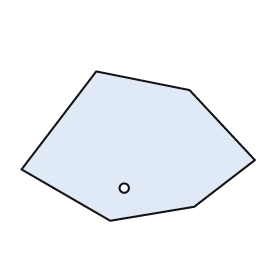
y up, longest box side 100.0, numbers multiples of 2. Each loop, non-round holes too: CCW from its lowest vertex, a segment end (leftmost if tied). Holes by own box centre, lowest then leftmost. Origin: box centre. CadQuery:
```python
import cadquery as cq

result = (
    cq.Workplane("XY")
    .moveTo(-12.0, -32.0)
    .lineTo(24.0, -26.0)
    .lineTo(50.0, -6.0)
    .lineTo(22.0, 24.0)
    .lineTo(-18.0, 32.0)
    .lineTo(-50.0, -10.0)
    .close()
    .moveTo(-6.0, -18.0)
    .circle(2.0)
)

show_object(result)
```